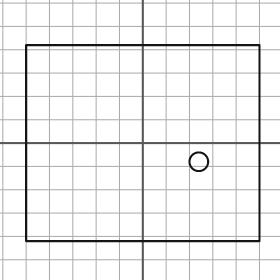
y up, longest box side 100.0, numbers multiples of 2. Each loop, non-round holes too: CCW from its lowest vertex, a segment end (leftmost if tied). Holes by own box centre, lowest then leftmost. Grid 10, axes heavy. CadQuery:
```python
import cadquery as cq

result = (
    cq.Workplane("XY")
    .moveTo(-50.0, -42.0)
    .lineTo(50.0, -42.0)
    .lineTo(50.0, 42.0)
    .lineTo(-50.0, 42.0)
    .close()
    .moveTo(24.0, -8.0)
    .circle(4.0)
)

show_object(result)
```